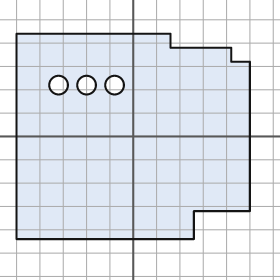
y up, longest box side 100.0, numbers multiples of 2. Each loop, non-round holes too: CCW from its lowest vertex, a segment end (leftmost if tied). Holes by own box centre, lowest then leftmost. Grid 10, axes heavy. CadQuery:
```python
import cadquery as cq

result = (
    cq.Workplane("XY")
    .moveTo(-50.0, -44.0)
    .lineTo(26.0, -44.0)
    .lineTo(26.0, -32.0)
    .lineTo(50.0, -32.0)
    .lineTo(50.0, 32.0)
    .lineTo(42.0, 32.0)
    .lineTo(42.0, 38.0)
    .lineTo(16.0, 38.0)
    .lineTo(16.0, 44.0)
    .lineTo(-50.0, 44.0)
    .close()
    .moveTo(-32.0, 22.0)
    .circle(4.0)
    .moveTo(-20.0, 22.0)
    .circle(4.0)
    .moveTo(-8.0, 22.0)
    .circle(4.0)
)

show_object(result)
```